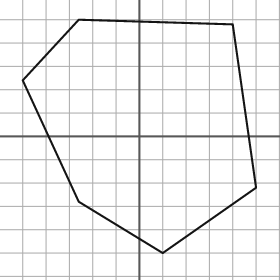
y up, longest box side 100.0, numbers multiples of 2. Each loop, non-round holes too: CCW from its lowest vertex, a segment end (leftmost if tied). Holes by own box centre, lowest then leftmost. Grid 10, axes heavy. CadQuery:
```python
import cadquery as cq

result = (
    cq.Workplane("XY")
    .moveTo(10.0, -50.0)
    .lineTo(50.0, -22.0)
    .lineTo(40.0, 48.0)
    .lineTo(-26.0, 50.0)
    .lineTo(-50.0, 24.0)
    .lineTo(-26.0, -28.0)
    .close()
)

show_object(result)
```